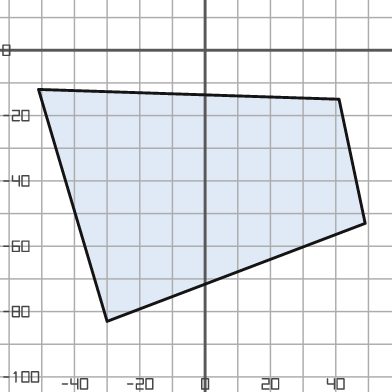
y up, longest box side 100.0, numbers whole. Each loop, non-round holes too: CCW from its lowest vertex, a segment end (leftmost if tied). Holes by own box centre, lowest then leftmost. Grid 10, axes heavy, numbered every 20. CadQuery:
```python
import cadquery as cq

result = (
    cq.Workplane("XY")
    .moveTo(-30.0, -83.0)
    .lineTo(49.0, -53.0)
    .lineTo(41.0, -15.0)
    .lineTo(-51.0, -12.0)
    .close()
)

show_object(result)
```